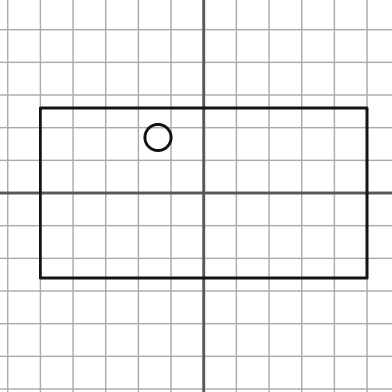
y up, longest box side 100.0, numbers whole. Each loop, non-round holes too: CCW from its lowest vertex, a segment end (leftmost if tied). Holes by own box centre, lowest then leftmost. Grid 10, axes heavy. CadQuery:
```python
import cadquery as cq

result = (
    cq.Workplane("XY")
    .moveTo(-50.0, -26.0)
    .lineTo(50.0, -26.0)
    .lineTo(50.0, 26.0)
    .lineTo(-50.0, 26.0)
    .close()
    .moveTo(-14.0, 17.0)
    .circle(4.0)
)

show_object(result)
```